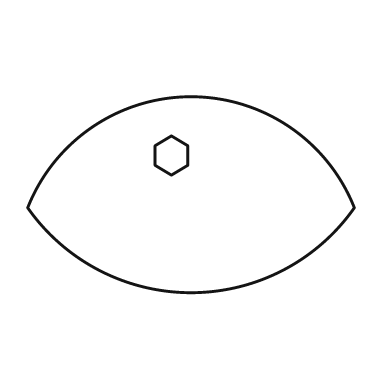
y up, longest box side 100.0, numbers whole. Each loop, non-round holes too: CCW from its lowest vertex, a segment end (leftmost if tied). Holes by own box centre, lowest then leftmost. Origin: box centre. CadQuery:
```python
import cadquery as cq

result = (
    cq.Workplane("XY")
    .moveTo(-50.0, -4.0)
    .threePointArc((0.0, -30.0), (50.0, -4.0))
    .threePointArc((0.0, 30.0), (-50.0, -4.0))
    .close()
    .moveTo(-6.0, 6.0)
    .lineTo(-1.0, 9.0)
    .lineTo(-1.0, 15.0)
    .lineTo(-6.0, 18.0)
    .lineTo(-11.0, 15.0)
    .lineTo(-11.0, 9.0)
    .close()
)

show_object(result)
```